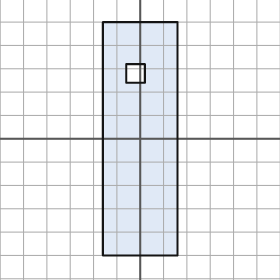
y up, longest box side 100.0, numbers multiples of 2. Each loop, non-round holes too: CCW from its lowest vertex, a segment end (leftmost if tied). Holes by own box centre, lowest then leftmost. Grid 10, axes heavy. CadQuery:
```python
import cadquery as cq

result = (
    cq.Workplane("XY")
    .moveTo(-16.0, -50.0)
    .lineTo(16.0, -50.0)
    .lineTo(16.0, 50.0)
    .lineTo(-16.0, 50.0)
    .close()
    .moveTo(-6.0, 24.0)
    .lineTo(2.0, 24.0)
    .lineTo(2.0, 32.0)
    .lineTo(-6.0, 32.0)
    .close()
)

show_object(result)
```